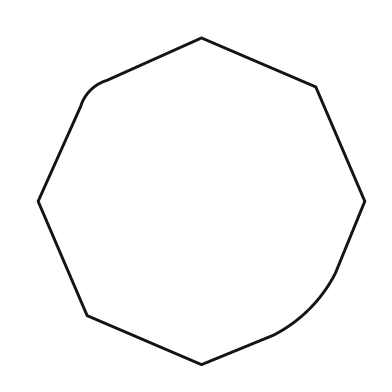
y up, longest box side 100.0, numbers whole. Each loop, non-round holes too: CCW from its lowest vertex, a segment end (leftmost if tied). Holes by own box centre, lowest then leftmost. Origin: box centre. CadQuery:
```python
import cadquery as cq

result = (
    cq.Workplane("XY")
    .moveTo(0.0, -50.0)
    .lineTo(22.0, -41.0)
    .threePointArc((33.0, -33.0), (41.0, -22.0))
    .lineTo(50.0, 0.0)
    .lineTo(35.0, 35.0)
    .lineTo(0.0, 50.0)
    .lineTo(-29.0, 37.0)
    .threePointArc((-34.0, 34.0), (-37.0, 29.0))
    .lineTo(-50.0, 0.0)
    .lineTo(-35.0, -35.0)
    .close()
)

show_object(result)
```